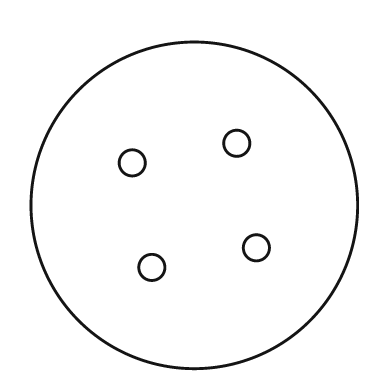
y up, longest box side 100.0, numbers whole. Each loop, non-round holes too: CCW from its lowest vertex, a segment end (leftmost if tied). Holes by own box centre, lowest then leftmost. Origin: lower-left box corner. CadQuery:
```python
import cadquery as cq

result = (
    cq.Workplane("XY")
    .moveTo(50.0, 50.0)
    .circle(50.0)
    .moveTo(37.0, 31.0)
    .circle(4.0)
    .moveTo(69.0, 37.0)
    .circle(4.0)
    .moveTo(31.0, 63.0)
    .circle(4.0)
    .moveTo(63.0, 69.0)
    .circle(4.0)
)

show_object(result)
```